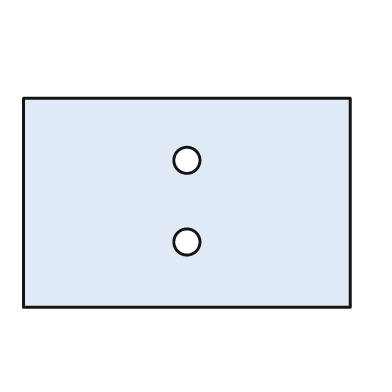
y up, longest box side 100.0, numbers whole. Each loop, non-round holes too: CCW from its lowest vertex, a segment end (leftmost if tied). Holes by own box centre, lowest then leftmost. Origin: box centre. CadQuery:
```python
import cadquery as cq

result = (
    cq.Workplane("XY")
    .moveTo(-50.0, -32.0)
    .lineTo(50.0, -32.0)
    .lineTo(50.0, 32.0)
    .lineTo(-50.0, 32.0)
    .close()
    .moveTo(0.0, -12.0)
    .circle(4.0)
    .moveTo(0.0, 13.0)
    .circle(4.0)
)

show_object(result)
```